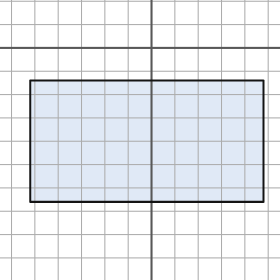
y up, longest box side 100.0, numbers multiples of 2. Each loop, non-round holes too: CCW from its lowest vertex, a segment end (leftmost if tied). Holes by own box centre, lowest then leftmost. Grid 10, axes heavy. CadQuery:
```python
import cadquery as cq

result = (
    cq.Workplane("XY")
    .moveTo(-52.0, -66.0)
    .lineTo(48.0, -66.0)
    .lineTo(48.0, -14.0)
    .lineTo(-52.0, -14.0)
    .close()
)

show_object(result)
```